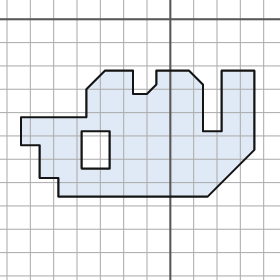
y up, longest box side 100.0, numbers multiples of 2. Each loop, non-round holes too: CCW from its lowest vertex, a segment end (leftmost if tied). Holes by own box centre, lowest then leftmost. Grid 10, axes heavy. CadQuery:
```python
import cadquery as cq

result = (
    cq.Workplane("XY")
    .moveTo(-48.0, -76.0)
    .lineTo(16.0, -76.0)
    .lineTo(36.0, -56.0)
    .lineTo(36.0, -22.0)
    .lineTo(22.0, -22.0)
    .lineTo(22.0, -48.0)
    .lineTo(14.0, -48.0)
    .lineTo(14.0, -28.0)
    .lineTo(8.0, -22.0)
    .lineTo(-6.0, -22.0)
    .lineTo(-6.0, -28.0)
    .lineTo(-10.0, -32.0)
    .lineTo(-16.0, -32.0)
    .lineTo(-16.0, -22.0)
    .lineTo(-28.0, -22.0)
    .lineTo(-36.0, -30.0)
    .lineTo(-36.0, -42.0)
    .lineTo(-64.0, -42.0)
    .lineTo(-64.0, -54.0)
    .lineTo(-56.0, -54.0)
    .lineTo(-56.0, -68.0)
    .lineTo(-48.0, -68.0)
    .close()
    .moveTo(-38.0, -64.0)
    .lineTo(-26.0, -64.0)
    .lineTo(-26.0, -48.0)
    .lineTo(-38.0, -48.0)
    .close()
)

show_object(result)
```